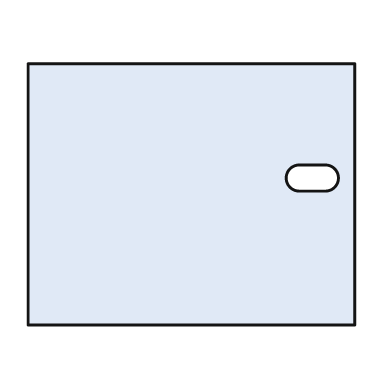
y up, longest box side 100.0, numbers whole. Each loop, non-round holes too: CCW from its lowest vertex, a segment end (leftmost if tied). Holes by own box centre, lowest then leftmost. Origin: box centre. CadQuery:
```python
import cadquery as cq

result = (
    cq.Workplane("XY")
    .moveTo(-50.0, -40.0)
    .lineTo(50.0, -40.0)
    .lineTo(50.0, 40.0)
    .lineTo(-50.0, 40.0)
    .close()
    .moveTo(33.0, 1.0)
    .lineTo(41.0, 1.0)
    .threePointArc((45.0, 5.0), (41.0, 9.0))
    .lineTo(33.0, 9.0)
    .threePointArc((29.0, 5.0), (33.0, 1.0))
    .close()
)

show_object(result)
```